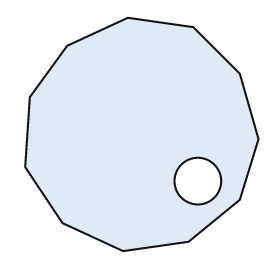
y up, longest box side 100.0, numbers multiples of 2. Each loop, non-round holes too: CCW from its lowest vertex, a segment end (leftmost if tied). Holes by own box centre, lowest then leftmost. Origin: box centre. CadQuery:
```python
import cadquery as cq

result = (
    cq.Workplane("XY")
    .moveTo(-8.0, -50.0)
    .lineTo(20.0, -46.0)
    .lineTo(42.0, -28.0)
    .lineTo(50.0, -2.0)
    .lineTo(42.0, 26.0)
    .lineTo(22.0, 46.0)
    .lineTo(-6.0, 50.0)
    .lineTo(-32.0, 38.0)
    .lineTo(-48.0, 16.0)
    .lineTo(-50.0, -14.0)
    .lineTo(-34.0, -38.0)
    .close()
    .moveTo(24.0, -20.0)
    .circle(10.0)
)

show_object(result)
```